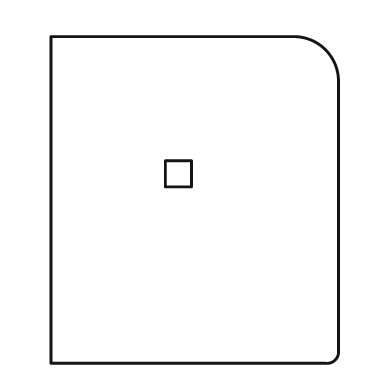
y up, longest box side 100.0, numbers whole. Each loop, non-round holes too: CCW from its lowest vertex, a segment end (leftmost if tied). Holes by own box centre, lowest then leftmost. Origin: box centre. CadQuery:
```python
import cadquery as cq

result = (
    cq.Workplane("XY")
    .moveTo(-44.0, -50.0)
    .lineTo(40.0, -50.0)
    .threePointArc((43.0, -49.0), (44.0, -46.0))
    .lineTo(44.0, 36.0)
    .threePointArc((40.0, 46.0), (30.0, 50.0))
    .lineTo(-44.0, 50.0)
    .close()
    .moveTo(-9.0, 4.0)
    .lineTo(-1.0, 4.0)
    .lineTo(-1.0, 12.0)
    .lineTo(-9.0, 12.0)
    .close()
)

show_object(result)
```